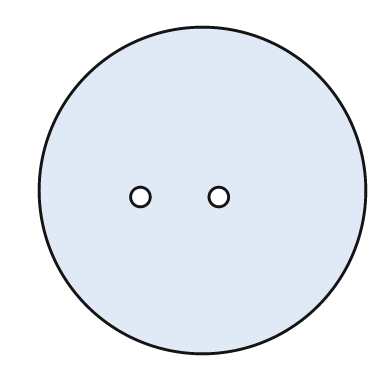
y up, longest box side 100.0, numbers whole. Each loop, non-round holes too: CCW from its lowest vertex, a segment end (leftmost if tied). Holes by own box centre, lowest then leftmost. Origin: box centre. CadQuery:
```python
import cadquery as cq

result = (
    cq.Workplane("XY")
    .moveTo(0.0, 0.0)
    .circle(50.0)
    .moveTo(-19.0, -2.0)
    .circle(3.0)
    .moveTo(5.0, -2.0)
    .circle(3.0)
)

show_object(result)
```